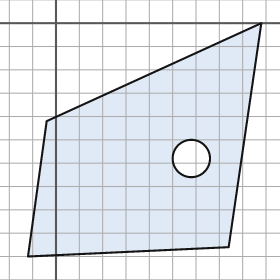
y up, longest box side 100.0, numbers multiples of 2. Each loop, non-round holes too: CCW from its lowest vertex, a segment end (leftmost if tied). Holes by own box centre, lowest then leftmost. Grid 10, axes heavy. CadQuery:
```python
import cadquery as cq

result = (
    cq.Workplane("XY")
    .moveTo(-12.0, -100.0)
    .lineTo(74.0, -96.0)
    .lineTo(88.0, 0.0)
    .lineTo(-4.0, -42.0)
    .close()
    .moveTo(58.0, -58.0)
    .circle(8.0)
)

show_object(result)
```